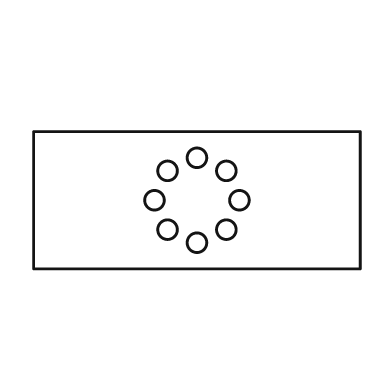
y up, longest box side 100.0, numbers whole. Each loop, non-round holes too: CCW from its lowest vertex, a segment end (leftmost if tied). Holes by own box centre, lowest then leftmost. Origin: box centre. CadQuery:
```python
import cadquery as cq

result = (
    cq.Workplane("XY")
    .moveTo(-50.0, -21.0)
    .lineTo(50.0, -21.0)
    .lineTo(50.0, 21.0)
    .lineTo(-50.0, 21.0)
    .close()
    .moveTo(0.0, -13.0)
    .circle(3.0)
    .moveTo(-9.0, -9.0)
    .circle(3.0)
    .moveTo(9.0, -9.0)
    .circle(3.0)
    .moveTo(-13.0, 0.0)
    .circle(3.0)
    .moveTo(13.0, 0.0)
    .circle(3.0)
    .moveTo(-9.0, 9.0)
    .circle(3.0)
    .moveTo(9.0, 9.0)
    .circle(3.0)
    .moveTo(0.0, 13.0)
    .circle(3.0)
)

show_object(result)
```